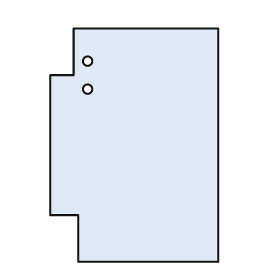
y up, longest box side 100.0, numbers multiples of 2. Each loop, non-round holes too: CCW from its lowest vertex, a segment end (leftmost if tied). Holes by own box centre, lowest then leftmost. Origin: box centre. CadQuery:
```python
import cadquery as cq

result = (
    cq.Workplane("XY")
    .moveTo(-24.0, -50.0)
    .lineTo(36.0, -50.0)
    .lineTo(36.0, 50.0)
    .lineTo(-26.0, 50.0)
    .lineTo(-26.0, 30.0)
    .lineTo(-36.0, 30.0)
    .lineTo(-36.0, -30.0)
    .lineTo(-24.0, -30.0)
    .close()
    .moveTo(-20.0, 24.0)
    .circle(2.0)
    .moveTo(-20.0, 36.0)
    .circle(2.0)
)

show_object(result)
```